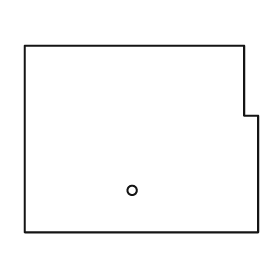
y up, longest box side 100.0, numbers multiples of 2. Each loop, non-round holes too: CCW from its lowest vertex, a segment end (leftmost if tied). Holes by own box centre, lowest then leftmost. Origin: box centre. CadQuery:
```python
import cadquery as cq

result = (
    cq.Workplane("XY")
    .moveTo(-50.0, -40.0)
    .lineTo(50.0, -40.0)
    .lineTo(50.0, 10.0)
    .lineTo(44.0, 10.0)
    .lineTo(44.0, 40.0)
    .lineTo(-50.0, 40.0)
    .close()
    .moveTo(-4.0, -22.0)
    .circle(2.0)
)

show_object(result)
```